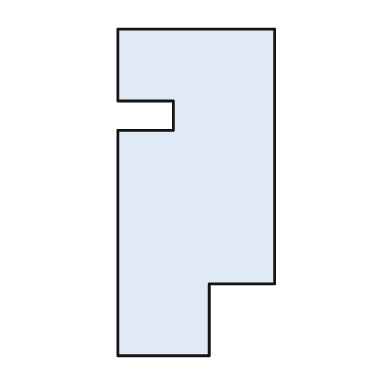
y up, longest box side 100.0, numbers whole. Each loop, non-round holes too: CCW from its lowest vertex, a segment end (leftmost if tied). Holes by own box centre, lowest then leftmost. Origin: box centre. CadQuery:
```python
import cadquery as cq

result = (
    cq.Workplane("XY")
    .moveTo(-24.0, -50.0)
    .lineTo(4.0, -50.0)
    .lineTo(4.0, -28.0)
    .lineTo(24.0, -28.0)
    .lineTo(24.0, 50.0)
    .lineTo(-24.0, 50.0)
    .lineTo(-24.0, 28.0)
    .lineTo(-7.0, 28.0)
    .lineTo(-7.0, 19.0)
    .lineTo(-24.0, 19.0)
    .close()
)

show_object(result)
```